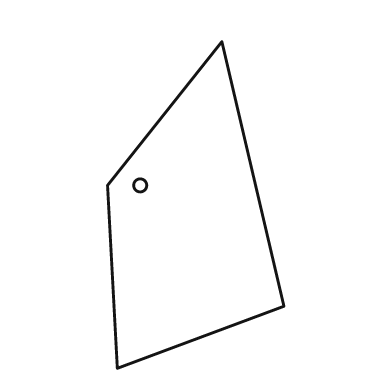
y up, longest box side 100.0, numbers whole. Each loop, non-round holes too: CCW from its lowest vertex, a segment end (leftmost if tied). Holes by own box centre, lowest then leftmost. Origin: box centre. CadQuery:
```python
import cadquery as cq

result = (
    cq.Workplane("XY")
    .moveTo(-24.0, -50.0)
    .lineTo(27.0, -31.0)
    .lineTo(8.0, 50.0)
    .lineTo(-27.0, 6.0)
    .close()
    .moveTo(-17.0, 6.0)
    .circle(2.0)
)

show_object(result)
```